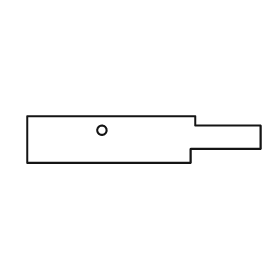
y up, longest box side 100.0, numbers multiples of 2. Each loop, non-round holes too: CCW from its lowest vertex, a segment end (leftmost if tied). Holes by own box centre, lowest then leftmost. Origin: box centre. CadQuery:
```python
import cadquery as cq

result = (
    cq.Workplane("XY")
    .moveTo(-50.0, -10.0)
    .lineTo(20.0, -10.0)
    .lineTo(20.0, -4.0)
    .lineTo(50.0, -4.0)
    .lineTo(50.0, 6.0)
    .lineTo(22.0, 6.0)
    .lineTo(22.0, 10.0)
    .lineTo(-50.0, 10.0)
    .close()
    .moveTo(-18.0, 4.0)
    .circle(2.0)
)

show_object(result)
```